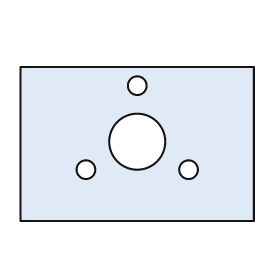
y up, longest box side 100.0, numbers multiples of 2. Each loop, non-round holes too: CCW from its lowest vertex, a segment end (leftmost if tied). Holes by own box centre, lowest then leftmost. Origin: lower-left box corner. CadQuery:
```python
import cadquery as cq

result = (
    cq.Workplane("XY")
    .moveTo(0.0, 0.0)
    .lineTo(100.0, 0.0)
    .lineTo(100.0, 66.0)
    .lineTo(0.0, 66.0)
    .close()
    .moveTo(28.0, 22.0)
    .circle(4.0)
    .moveTo(72.0, 22.0)
    .circle(4.0)
    .moveTo(50.0, 34.0)
    .circle(12.0)
    .moveTo(50.0, 58.0)
    .circle(4.0)
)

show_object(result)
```